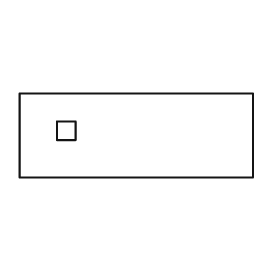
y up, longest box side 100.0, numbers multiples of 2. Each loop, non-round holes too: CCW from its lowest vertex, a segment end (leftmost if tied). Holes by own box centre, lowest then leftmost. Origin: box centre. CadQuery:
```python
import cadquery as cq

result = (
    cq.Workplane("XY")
    .moveTo(-50.0, -18.0)
    .lineTo(50.0, -18.0)
    .lineTo(50.0, 18.0)
    .lineTo(-50.0, 18.0)
    .close()
    .moveTo(-34.0, -2.0)
    .lineTo(-26.0, -2.0)
    .lineTo(-26.0, 6.0)
    .lineTo(-34.0, 6.0)
    .close()
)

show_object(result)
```